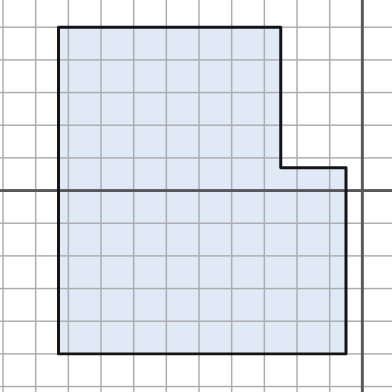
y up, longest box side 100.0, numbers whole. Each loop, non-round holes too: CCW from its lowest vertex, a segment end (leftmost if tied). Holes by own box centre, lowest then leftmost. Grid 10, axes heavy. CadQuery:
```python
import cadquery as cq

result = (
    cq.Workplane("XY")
    .moveTo(-93.0, -50.0)
    .lineTo(-5.0, -50.0)
    .lineTo(-5.0, 7.0)
    .lineTo(-25.0, 7.0)
    .lineTo(-25.0, 50.0)
    .lineTo(-93.0, 50.0)
    .close()
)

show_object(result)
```